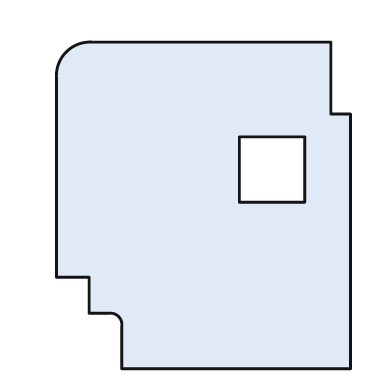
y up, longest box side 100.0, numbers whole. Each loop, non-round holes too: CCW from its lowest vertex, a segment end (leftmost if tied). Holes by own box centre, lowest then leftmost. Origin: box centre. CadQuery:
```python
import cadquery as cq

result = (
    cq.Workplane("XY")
    .moveTo(-25.0, -50.0)
    .lineTo(45.0, -50.0)
    .lineTo(45.0, 28.0)
    .lineTo(39.0, 28.0)
    .lineTo(39.0, 50.0)
    .lineTo(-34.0, 50.0)
    .threePointArc((-42.0, 47.0), (-45.0, 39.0))
    .lineTo(-45.0, -22.0)
    .lineTo(-35.0, -22.0)
    .lineTo(-35.0, -33.0)
    .lineTo(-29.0, -33.0)
    .threePointArc((-26.0, -34.0), (-25.0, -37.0))
    .close()
    .moveTo(11.0, 1.0)
    .lineTo(31.0, 1.0)
    .lineTo(31.0, 21.0)
    .lineTo(11.0, 21.0)
    .close()
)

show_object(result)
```